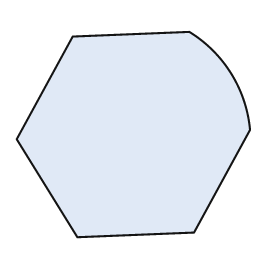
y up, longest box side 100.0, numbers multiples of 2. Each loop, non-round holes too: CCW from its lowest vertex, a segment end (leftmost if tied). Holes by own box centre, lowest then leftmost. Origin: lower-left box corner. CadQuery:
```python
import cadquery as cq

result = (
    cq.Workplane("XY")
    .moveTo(26.0, 0.0)
    .lineTo(76.0, 2.0)
    .lineTo(100.0, 46.0)
    .threePointArc((92.0, 70.0), (74.0, 88.0))
    .lineTo(24.0, 86.0)
    .lineTo(0.0, 42.0)
    .close()
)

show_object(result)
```